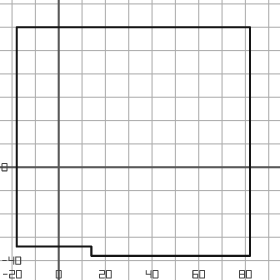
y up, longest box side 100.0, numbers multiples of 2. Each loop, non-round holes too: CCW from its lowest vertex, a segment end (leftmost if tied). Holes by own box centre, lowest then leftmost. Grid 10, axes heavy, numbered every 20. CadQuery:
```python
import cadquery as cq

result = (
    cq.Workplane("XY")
    .moveTo(14.0, -38.0)
    .lineTo(82.0, -38.0)
    .lineTo(82.0, 60.0)
    .lineTo(-18.0, 60.0)
    .lineTo(-18.0, -34.0)
    .lineTo(14.0, -34.0)
    .close()
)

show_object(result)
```